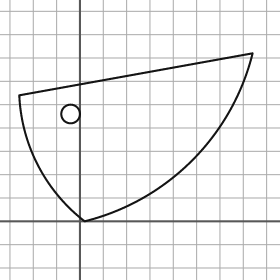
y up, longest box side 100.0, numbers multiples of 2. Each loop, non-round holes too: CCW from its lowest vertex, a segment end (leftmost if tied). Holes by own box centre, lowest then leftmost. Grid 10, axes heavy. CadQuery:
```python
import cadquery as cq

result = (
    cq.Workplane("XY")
    .moveTo(2.0, 0.0)
    .threePointArc((48.0, 26.0), (74.0, 72.0))
    .lineTo(-26.0, 54.0)
    .threePointArc((-18.0, 24.0), (2.0, 0.0))
    .close()
    .moveTo(-4.0, 46.0)
    .circle(4.0)
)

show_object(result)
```